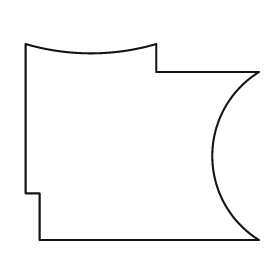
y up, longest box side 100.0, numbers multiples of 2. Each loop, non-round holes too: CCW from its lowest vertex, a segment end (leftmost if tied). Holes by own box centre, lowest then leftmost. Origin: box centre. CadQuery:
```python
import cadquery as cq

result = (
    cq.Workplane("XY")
    .moveTo(-44.0, -42.0)
    .lineTo(50.0, -42.0)
    .threePointArc((30.0, -6.0), (50.0, 30.0))
    .lineTo(6.0, 30.0)
    .lineTo(6.0, 42.0)
    .threePointArc((-22.0, 38.0), (-50.0, 42.0))
    .lineTo(-50.0, -22.0)
    .lineTo(-44.0, -22.0)
    .close()
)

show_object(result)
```